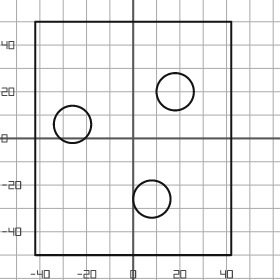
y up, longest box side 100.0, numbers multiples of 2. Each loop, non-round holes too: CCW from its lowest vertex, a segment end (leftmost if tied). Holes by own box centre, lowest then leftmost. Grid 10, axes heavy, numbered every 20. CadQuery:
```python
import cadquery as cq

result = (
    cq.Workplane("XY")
    .moveTo(-42.0, -50.0)
    .lineTo(42.0, -50.0)
    .lineTo(42.0, 50.0)
    .lineTo(-42.0, 50.0)
    .close()
    .moveTo(8.0, -26.0)
    .circle(8.0)
    .moveTo(-26.0, 6.0)
    .circle(8.0)
    .moveTo(18.0, 20.0)
    .circle(8.0)
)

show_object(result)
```